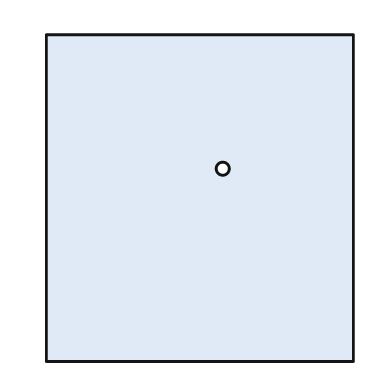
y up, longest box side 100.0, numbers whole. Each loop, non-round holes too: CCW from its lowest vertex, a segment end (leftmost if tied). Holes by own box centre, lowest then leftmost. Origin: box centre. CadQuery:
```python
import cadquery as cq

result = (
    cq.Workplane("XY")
    .moveTo(-47.0, -50.0)
    .lineTo(47.0, -50.0)
    .lineTo(47.0, 50.0)
    .lineTo(-47.0, 50.0)
    .close()
    .moveTo(7.0, 9.0)
    .circle(2.0)
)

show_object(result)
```